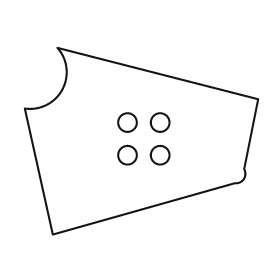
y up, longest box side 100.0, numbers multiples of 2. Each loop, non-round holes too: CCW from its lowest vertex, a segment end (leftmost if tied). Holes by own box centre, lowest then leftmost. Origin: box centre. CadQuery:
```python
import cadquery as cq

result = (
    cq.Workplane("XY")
    .moveTo(-38.0, -40.0)
    .lineTo(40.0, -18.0)
    .threePointArc((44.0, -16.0), (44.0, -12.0))
    .lineTo(50.0, 18.0)
    .lineTo(-36.0, 40.0)
    .threePointArc((-34.0, 22.0), (-50.0, 14.0))
    .close()
    .moveTo(-6.0, -6.0)
    .circle(4.0)
    .moveTo(8.0, -6.0)
    .circle(4.0)
    .moveTo(-6.0, 8.0)
    .circle(4.0)
    .moveTo(8.0, 8.0)
    .circle(4.0)
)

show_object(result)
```